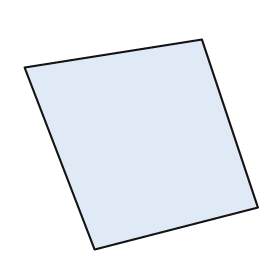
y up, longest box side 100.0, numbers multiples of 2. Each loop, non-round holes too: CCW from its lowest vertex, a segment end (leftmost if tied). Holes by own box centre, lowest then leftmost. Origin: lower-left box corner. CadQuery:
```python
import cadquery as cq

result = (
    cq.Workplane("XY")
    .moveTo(30.0, 0.0)
    .lineTo(100.0, 18.0)
    .lineTo(76.0, 90.0)
    .lineTo(0.0, 78.0)
    .close()
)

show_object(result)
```